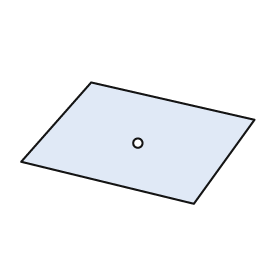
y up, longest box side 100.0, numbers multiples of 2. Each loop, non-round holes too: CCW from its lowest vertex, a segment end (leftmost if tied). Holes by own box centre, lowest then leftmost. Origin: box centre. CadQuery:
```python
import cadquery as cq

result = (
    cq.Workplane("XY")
    .moveTo(24.0, -26.0)
    .lineTo(50.0, 10.0)
    .lineTo(-20.0, 26.0)
    .lineTo(-50.0, -8.0)
    .close()
    .moveTo(0.0, 0.0)
    .circle(2.0)
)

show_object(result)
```